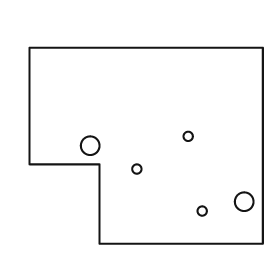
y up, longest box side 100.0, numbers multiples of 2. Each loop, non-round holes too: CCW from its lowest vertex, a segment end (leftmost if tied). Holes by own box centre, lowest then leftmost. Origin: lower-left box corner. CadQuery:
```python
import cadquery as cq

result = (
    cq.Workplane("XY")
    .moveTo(30.0, 0.0)
    .lineTo(100.0, 0.0)
    .lineTo(100.0, 84.0)
    .lineTo(0.0, 84.0)
    .lineTo(0.0, 34.0)
    .lineTo(30.0, 34.0)
    .close()
    .moveTo(74.0, 14.0)
    .circle(2.0)
    .moveTo(92.0, 18.0)
    .circle(4.0)
    .moveTo(46.0, 32.0)
    .circle(2.0)
    .moveTo(26.0, 42.0)
    .circle(4.0)
    .moveTo(68.0, 46.0)
    .circle(2.0)
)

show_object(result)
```